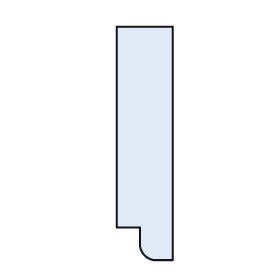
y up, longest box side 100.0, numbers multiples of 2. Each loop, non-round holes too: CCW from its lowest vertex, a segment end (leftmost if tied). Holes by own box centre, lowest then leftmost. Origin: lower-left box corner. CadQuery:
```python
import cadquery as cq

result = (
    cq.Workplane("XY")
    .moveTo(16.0, 0.0)
    .lineTo(24.0, 0.0)
    .lineTo(24.0, 100.0)
    .lineTo(0.0, 100.0)
    .lineTo(0.0, 14.0)
    .lineTo(10.0, 14.0)
    .lineTo(10.0, 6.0)
    .threePointArc((12.0, 2.0), (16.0, 0.0))
    .close()
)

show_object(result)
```